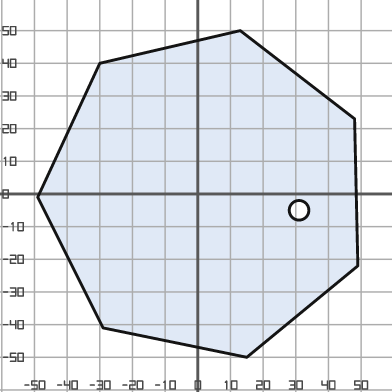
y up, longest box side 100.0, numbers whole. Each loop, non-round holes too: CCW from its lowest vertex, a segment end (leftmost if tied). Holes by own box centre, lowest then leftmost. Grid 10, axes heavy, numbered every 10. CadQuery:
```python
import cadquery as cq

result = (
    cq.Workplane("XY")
    .moveTo(15.0, -50.0)
    .lineTo(49.0, -22.0)
    .lineTo(48.0, 23.0)
    .lineTo(13.0, 50.0)
    .lineTo(-30.0, 40.0)
    .lineTo(-49.0, -1.0)
    .lineTo(-29.0, -41.0)
    .close()
    .moveTo(31.0, -5.0)
    .circle(3.0)
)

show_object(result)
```